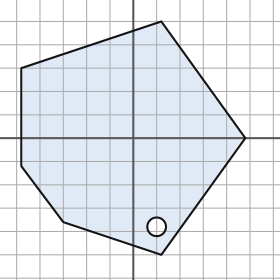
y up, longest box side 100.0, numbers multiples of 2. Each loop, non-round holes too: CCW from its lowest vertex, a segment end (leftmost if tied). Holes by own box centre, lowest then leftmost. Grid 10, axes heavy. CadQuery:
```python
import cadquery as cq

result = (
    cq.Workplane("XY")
    .moveTo(12.0, -50.0)
    .lineTo(48.0, 0.0)
    .lineTo(12.0, 50.0)
    .lineTo(-48.0, 30.0)
    .lineTo(-48.0, -12.0)
    .lineTo(-30.0, -36.0)
    .close()
    .moveTo(10.0, -38.0)
    .circle(4.0)
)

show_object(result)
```